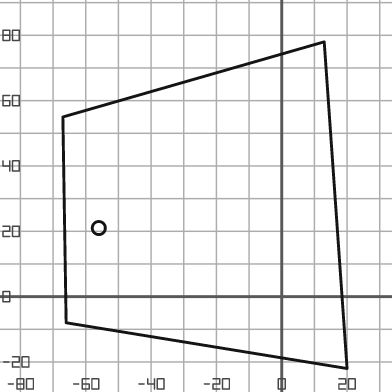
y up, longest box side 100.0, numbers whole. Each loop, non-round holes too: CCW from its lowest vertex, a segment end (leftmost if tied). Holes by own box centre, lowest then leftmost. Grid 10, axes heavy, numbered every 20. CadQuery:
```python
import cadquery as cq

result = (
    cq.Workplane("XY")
    .moveTo(20.0, -22.0)
    .lineTo(13.0, 78.0)
    .lineTo(-67.0, 55.0)
    .lineTo(-66.0, -8.0)
    .close()
    .moveTo(-56.0, 21.0)
    .circle(2.0)
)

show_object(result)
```